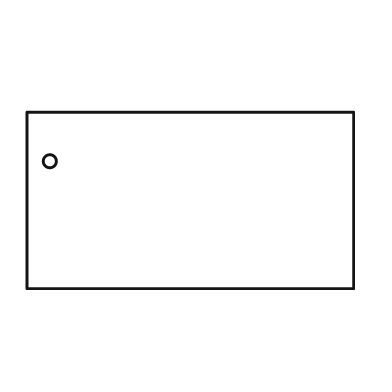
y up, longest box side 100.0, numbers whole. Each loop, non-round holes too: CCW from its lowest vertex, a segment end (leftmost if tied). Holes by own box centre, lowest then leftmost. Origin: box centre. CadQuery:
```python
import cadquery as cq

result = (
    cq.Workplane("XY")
    .moveTo(-50.0, -27.0)
    .lineTo(50.0, -27.0)
    .lineTo(50.0, 27.0)
    .lineTo(-50.0, 27.0)
    .close()
    .moveTo(-43.0, 12.0)
    .circle(2.0)
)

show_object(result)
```